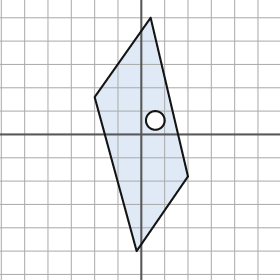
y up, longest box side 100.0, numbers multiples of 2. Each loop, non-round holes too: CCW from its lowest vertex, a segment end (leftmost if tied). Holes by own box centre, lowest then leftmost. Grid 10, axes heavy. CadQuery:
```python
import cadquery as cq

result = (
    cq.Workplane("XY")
    .moveTo(-2.0, -50.0)
    .lineTo(20.0, -18.0)
    .lineTo(4.0, 50.0)
    .lineTo(-20.0, 16.0)
    .close()
    .moveTo(6.0, 6.0)
    .circle(4.0)
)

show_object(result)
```